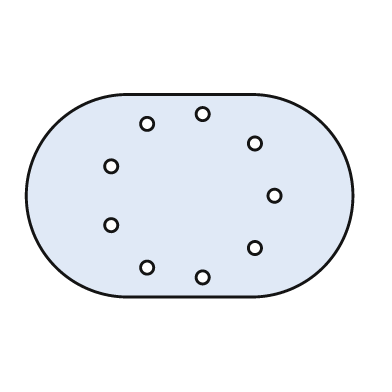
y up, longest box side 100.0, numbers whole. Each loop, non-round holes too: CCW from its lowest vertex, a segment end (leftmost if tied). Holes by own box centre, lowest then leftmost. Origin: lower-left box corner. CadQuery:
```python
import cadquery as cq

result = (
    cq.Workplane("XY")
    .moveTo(31.0, 0.0)
    .lineTo(69.0, 0.0)
    .threePointArc((100.0, 31.0), (69.0, 62.0))
    .lineTo(31.0, 62.0)
    .threePointArc((0.0, 31.0), (31.0, 0.0))
    .close()
    .moveTo(54.0, 6.0)
    .circle(2.0)
    .moveTo(37.0, 9.0)
    .circle(2.0)
    .moveTo(70.0, 15.0)
    .circle(2.0)
    .moveTo(26.0, 22.0)
    .circle(2.0)
    .moveTo(76.0, 31.0)
    .circle(2.0)
    .moveTo(26.0, 40.0)
    .circle(2.0)
    .moveTo(70.0, 47.0)
    .circle(2.0)
    .moveTo(37.0, 53.0)
    .circle(2.0)
    .moveTo(54.0, 56.0)
    .circle(2.0)
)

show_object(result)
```